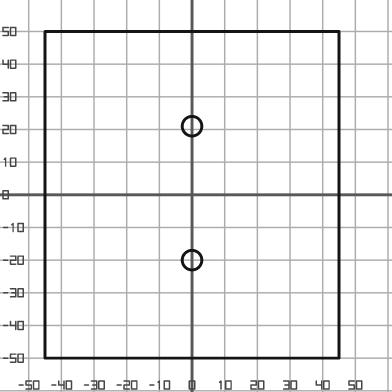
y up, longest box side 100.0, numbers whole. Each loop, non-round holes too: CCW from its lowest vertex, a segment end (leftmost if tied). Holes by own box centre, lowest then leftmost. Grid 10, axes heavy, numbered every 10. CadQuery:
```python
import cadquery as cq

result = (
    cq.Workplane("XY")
    .moveTo(-45.0, -50.0)
    .lineTo(45.0, -50.0)
    .lineTo(45.0, 50.0)
    .lineTo(-45.0, 50.0)
    .close()
    .moveTo(0.0, -20.0)
    .circle(3.0)
    .moveTo(0.0, 21.0)
    .circle(3.0)
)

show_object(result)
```